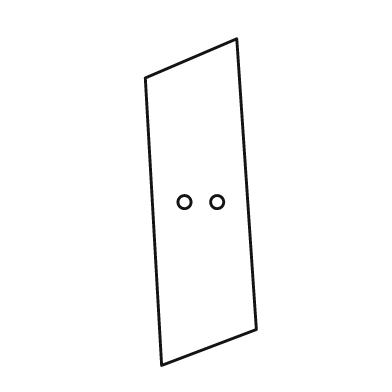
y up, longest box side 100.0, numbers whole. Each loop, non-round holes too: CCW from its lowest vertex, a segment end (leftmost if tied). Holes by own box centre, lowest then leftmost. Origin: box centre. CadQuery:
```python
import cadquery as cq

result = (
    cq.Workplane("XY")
    .moveTo(-12.0, -50.0)
    .lineTo(17.0, -39.0)
    .lineTo(11.0, 50.0)
    .lineTo(-17.0, 38.0)
    .close()
    .moveTo(-5.0, 0.0)
    .circle(2.0)
    .moveTo(5.0, 0.0)
    .circle(2.0)
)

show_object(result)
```